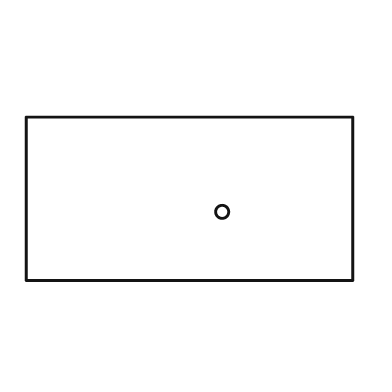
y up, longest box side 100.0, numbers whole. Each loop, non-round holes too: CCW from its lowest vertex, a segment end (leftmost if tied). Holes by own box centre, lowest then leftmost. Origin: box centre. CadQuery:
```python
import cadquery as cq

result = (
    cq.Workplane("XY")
    .moveTo(-50.0, -25.0)
    .lineTo(50.0, -25.0)
    .lineTo(50.0, 25.0)
    .lineTo(-50.0, 25.0)
    .close()
    .moveTo(10.0, -4.0)
    .circle(2.0)
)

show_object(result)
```